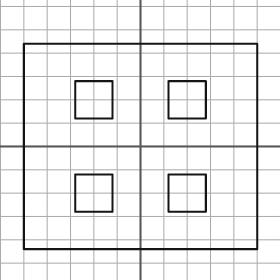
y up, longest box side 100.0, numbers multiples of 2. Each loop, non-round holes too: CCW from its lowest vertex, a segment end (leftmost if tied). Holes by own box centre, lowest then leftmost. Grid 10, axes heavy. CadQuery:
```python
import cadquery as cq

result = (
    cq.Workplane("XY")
    .moveTo(-50.0, -44.0)
    .lineTo(50.0, -44.0)
    .lineTo(50.0, 44.0)
    .lineTo(-50.0, 44.0)
    .close()
    .moveTo(-28.0, -28.0)
    .lineTo(-12.0, -28.0)
    .lineTo(-12.0, -12.0)
    .lineTo(-28.0, -12.0)
    .close()
    .moveTo(12.0, -28.0)
    .lineTo(28.0, -28.0)
    .lineTo(28.0, -12.0)
    .lineTo(12.0, -12.0)
    .close()
    .moveTo(-28.0, 12.0)
    .lineTo(-12.0, 12.0)
    .lineTo(-12.0, 28.0)
    .lineTo(-28.0, 28.0)
    .close()
    .moveTo(12.0, 12.0)
    .lineTo(28.0, 12.0)
    .lineTo(28.0, 28.0)
    .lineTo(12.0, 28.0)
    .close()
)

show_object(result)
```